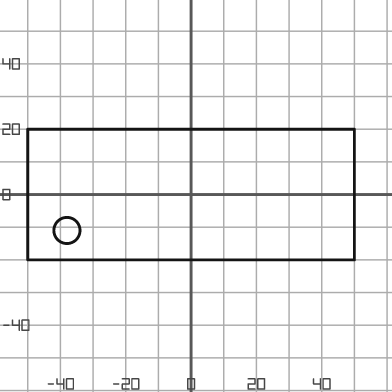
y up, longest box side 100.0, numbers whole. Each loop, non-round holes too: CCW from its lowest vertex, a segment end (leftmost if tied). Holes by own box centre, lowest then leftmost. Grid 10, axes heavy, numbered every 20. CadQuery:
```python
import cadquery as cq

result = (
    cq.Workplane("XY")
    .moveTo(-50.0, -20.0)
    .lineTo(50.0, -20.0)
    .lineTo(50.0, 20.0)
    .lineTo(-50.0, 20.0)
    .close()
    .moveTo(-38.0, -11.0)
    .circle(4.0)
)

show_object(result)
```